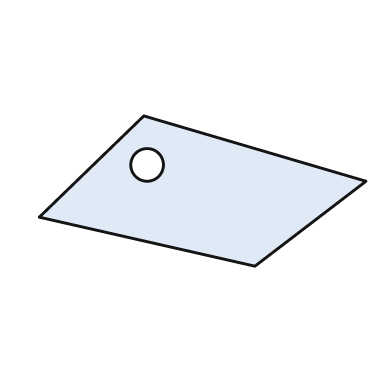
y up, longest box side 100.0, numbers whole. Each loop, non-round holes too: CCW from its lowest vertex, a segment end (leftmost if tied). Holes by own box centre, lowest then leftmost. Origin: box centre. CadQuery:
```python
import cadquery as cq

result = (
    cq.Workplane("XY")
    .moveTo(16.0, -23.0)
    .lineTo(50.0, 3.0)
    .lineTo(-18.0, 23.0)
    .lineTo(-50.0, -8.0)
    .close()
    .moveTo(-17.0, 8.0)
    .circle(5.0)
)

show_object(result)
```